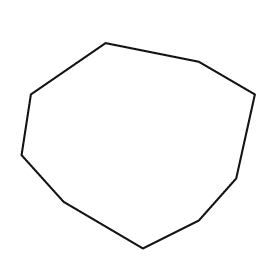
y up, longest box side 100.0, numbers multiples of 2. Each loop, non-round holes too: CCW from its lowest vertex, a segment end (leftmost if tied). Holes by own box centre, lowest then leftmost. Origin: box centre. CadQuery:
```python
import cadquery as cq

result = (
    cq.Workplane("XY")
    .moveTo(2.0, -44.0)
    .lineTo(26.0, -32.0)
    .lineTo(42.0, -14.0)
    .lineTo(50.0, 22.0)
    .lineTo(26.0, 36.0)
    .lineTo(-14.0, 44.0)
    .lineTo(-46.0, 22.0)
    .lineTo(-50.0, -4.0)
    .lineTo(-32.0, -24.0)
    .close()
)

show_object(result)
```